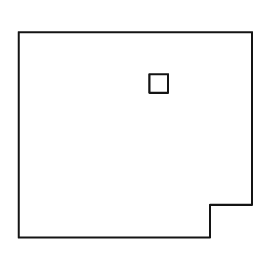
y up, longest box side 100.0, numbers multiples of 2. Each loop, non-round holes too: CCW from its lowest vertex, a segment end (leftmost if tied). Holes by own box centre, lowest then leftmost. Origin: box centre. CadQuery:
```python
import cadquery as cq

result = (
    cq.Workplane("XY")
    .moveTo(-50.0, -44.0)
    .lineTo(32.0, -44.0)
    .lineTo(32.0, -30.0)
    .lineTo(50.0, -30.0)
    .lineTo(50.0, 44.0)
    .lineTo(-50.0, 44.0)
    .close()
    .moveTo(6.0, 18.0)
    .lineTo(14.0, 18.0)
    .lineTo(14.0, 26.0)
    .lineTo(6.0, 26.0)
    .close()
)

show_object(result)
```